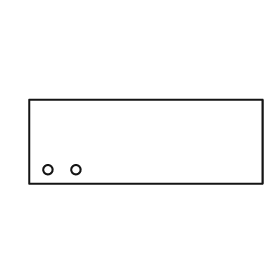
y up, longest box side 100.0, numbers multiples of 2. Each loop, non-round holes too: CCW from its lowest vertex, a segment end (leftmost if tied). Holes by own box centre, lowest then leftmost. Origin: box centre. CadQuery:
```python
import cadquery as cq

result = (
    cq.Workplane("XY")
    .moveTo(-50.0, -18.0)
    .lineTo(50.0, -18.0)
    .lineTo(50.0, 18.0)
    .lineTo(-50.0, 18.0)
    .close()
    .moveTo(-42.0, -12.0)
    .circle(2.0)
    .moveTo(-30.0, -12.0)
    .circle(2.0)
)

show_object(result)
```